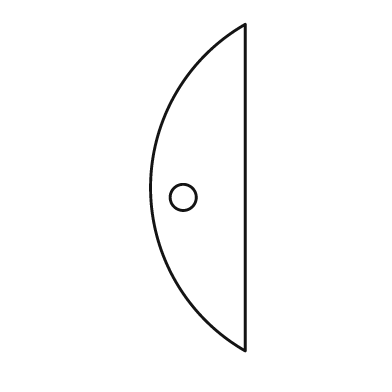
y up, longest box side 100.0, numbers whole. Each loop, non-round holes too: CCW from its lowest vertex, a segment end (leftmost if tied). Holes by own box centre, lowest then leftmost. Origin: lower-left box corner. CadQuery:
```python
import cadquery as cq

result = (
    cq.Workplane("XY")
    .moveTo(29.0, 0.0)
    .lineTo(29.0, 100.0)
    .threePointArc((0.0, 50.0), (29.0, 0.0))
    .close()
    .moveTo(10.0, 47.0)
    .circle(4.0)
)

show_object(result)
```